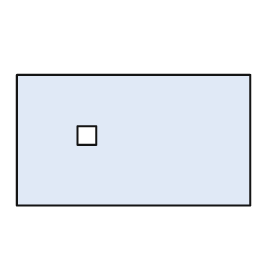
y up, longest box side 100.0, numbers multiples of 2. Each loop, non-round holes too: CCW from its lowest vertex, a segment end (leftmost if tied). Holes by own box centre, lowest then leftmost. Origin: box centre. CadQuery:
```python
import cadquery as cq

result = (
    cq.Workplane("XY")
    .moveTo(-50.0, -28.0)
    .lineTo(50.0, -28.0)
    .lineTo(50.0, 28.0)
    .lineTo(-50.0, 28.0)
    .close()
    .moveTo(-24.0, -2.0)
    .lineTo(-16.0, -2.0)
    .lineTo(-16.0, 6.0)
    .lineTo(-24.0, 6.0)
    .close()
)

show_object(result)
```